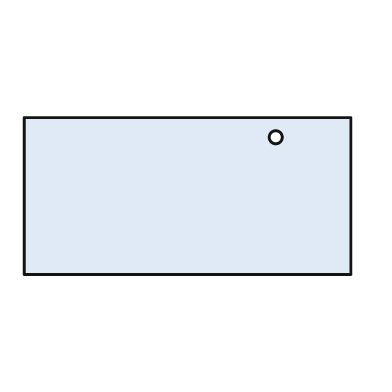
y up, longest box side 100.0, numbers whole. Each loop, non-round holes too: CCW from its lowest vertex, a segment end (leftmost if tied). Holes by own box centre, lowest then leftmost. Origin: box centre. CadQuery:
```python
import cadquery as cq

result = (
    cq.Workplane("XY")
    .moveTo(-50.0, -24.0)
    .lineTo(50.0, -24.0)
    .lineTo(50.0, 24.0)
    .lineTo(-50.0, 24.0)
    .close()
    .moveTo(27.0, 18.0)
    .circle(2.0)
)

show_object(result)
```